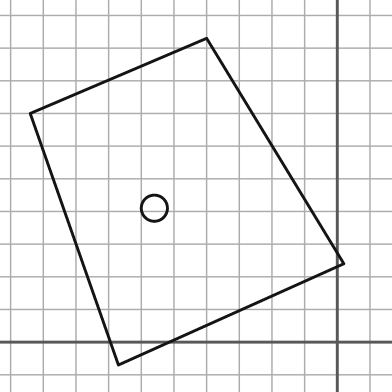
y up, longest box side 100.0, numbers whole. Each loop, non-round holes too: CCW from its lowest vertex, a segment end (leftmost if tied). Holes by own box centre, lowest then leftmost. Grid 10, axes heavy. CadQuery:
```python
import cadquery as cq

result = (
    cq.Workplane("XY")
    .moveTo(-67.0, -7.0)
    .lineTo(2.0, 24.0)
    .lineTo(-40.0, 93.0)
    .lineTo(-94.0, 70.0)
    .close()
    .moveTo(-56.0, 41.0)
    .circle(4.0)
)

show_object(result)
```